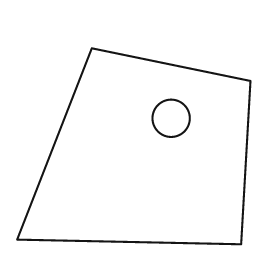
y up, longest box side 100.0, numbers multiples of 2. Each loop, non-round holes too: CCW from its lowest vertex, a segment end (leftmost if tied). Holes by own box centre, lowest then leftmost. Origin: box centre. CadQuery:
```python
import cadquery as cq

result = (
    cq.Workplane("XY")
    .moveTo(46.0, -42.0)
    .lineTo(50.0, 28.0)
    .lineTo(-18.0, 42.0)
    .lineTo(-50.0, -40.0)
    .close()
    .moveTo(16.0, 12.0)
    .circle(8.0)
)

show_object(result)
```